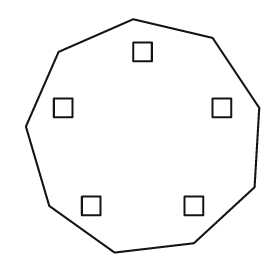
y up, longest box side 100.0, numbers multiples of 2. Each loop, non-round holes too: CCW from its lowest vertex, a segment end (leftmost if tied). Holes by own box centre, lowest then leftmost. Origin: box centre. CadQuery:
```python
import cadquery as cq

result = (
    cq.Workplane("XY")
    .moveTo(-12.0, -50.0)
    .lineTo(22.0, -46.0)
    .lineTo(48.0, -22.0)
    .lineTo(50.0, 12.0)
    .lineTo(30.0, 42.0)
    .lineTo(-4.0, 50.0)
    .lineTo(-36.0, 36.0)
    .lineTo(-50.0, 4.0)
    .lineTo(-40.0, -30.0)
    .close()
    .moveTo(-26.0, -34.0)
    .lineTo(-18.0, -34.0)
    .lineTo(-18.0, -26.0)
    .lineTo(-26.0, -26.0)
    .close()
    .moveTo(18.0, -34.0)
    .lineTo(26.0, -34.0)
    .lineTo(26.0, -26.0)
    .lineTo(18.0, -26.0)
    .close()
    .moveTo(-38.0, 8.0)
    .lineTo(-30.0, 8.0)
    .lineTo(-30.0, 16.0)
    .lineTo(-38.0, 16.0)
    .close()
    .moveTo(30.0, 8.0)
    .lineTo(38.0, 8.0)
    .lineTo(38.0, 16.0)
    .lineTo(30.0, 16.0)
    .close()
    .moveTo(-4.0, 32.0)
    .lineTo(4.0, 32.0)
    .lineTo(4.0, 40.0)
    .lineTo(-4.0, 40.0)
    .close()
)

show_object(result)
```